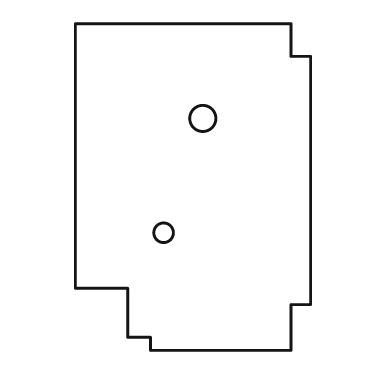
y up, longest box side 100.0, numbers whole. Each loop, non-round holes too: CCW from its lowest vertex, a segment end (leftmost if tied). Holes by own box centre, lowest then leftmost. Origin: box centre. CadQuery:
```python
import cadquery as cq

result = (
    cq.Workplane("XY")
    .moveTo(-13.0, -50.0)
    .lineTo(30.0, -50.0)
    .lineTo(30.0, -36.0)
    .lineTo(36.0, -36.0)
    .lineTo(36.0, 40.0)
    .lineTo(30.0, 40.0)
    .lineTo(30.0, 50.0)
    .lineTo(-36.0, 50.0)
    .lineTo(-36.0, -31.0)
    .lineTo(-20.0, -31.0)
    .lineTo(-20.0, -46.0)
    .lineTo(-13.0, -46.0)
    .close()
    .moveTo(-9.0, -14.0)
    .circle(3.0)
    .moveTo(3.0, 21.0)
    .circle(4.0)
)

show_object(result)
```